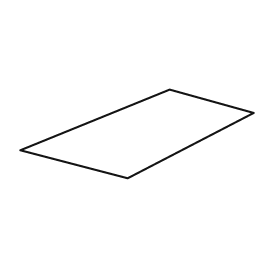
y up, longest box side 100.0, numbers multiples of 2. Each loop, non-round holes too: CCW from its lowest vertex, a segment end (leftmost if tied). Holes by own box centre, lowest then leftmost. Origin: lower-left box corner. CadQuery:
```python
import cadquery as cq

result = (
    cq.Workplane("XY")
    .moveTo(46.0, 0.0)
    .lineTo(100.0, 28.0)
    .lineTo(64.0, 38.0)
    .lineTo(0.0, 12.0)
    .close()
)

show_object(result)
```